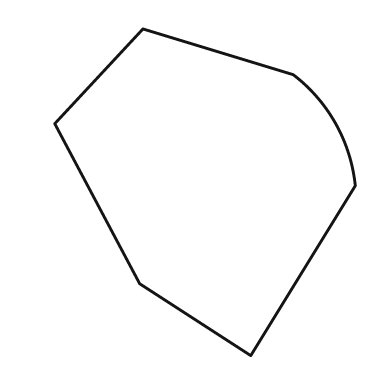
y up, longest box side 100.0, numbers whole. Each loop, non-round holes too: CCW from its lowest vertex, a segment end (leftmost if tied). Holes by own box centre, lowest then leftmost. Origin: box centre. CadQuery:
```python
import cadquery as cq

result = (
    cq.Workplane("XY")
    .moveTo(14.0, -50.0)
    .lineTo(46.0, 2.0)
    .threePointArc((40.0, 21.0), (27.0, 36.0))
    .lineTo(-19.0, 50.0)
    .lineTo(-46.0, 21.0)
    .lineTo(-20.0, -28.0)
    .close()
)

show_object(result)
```